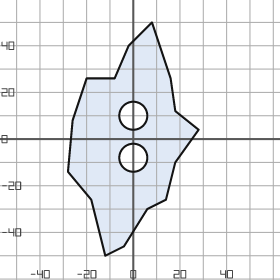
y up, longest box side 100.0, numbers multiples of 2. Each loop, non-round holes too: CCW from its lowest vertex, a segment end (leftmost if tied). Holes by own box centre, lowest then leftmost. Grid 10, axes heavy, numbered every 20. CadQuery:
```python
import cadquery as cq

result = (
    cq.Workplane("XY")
    .moveTo(-12.0, -50.0)
    .lineTo(-4.0, -46.0)
    .lineTo(6.0, -30.0)
    .lineTo(14.0, -26.0)
    .lineTo(18.0, -10.0)
    .lineTo(28.0, 4.0)
    .lineTo(18.0, 12.0)
    .lineTo(16.0, 26.0)
    .lineTo(8.0, 50.0)
    .lineTo(-2.0, 40.0)
    .lineTo(-8.0, 26.0)
    .lineTo(-20.0, 26.0)
    .lineTo(-26.0, 8.0)
    .lineTo(-28.0, -14.0)
    .lineTo(-18.0, -26.0)
    .close()
    .moveTo(0.0, -8.0)
    .circle(6.0)
    .moveTo(0.0, 10.0)
    .circle(6.0)
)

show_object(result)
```